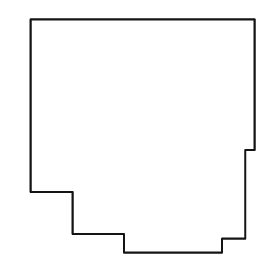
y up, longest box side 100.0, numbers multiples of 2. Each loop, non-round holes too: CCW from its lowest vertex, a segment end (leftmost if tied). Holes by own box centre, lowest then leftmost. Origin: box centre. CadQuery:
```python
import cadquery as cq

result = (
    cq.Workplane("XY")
    .moveTo(-8.0, -50.0)
    .lineTo(34.0, -50.0)
    .lineTo(34.0, -44.0)
    .lineTo(44.0, -44.0)
    .lineTo(44.0, -6.0)
    .lineTo(48.0, -6.0)
    .lineTo(48.0, 50.0)
    .lineTo(-48.0, 50.0)
    .lineTo(-48.0, -24.0)
    .lineTo(-30.0, -24.0)
    .lineTo(-30.0, -42.0)
    .lineTo(-8.0, -42.0)
    .close()
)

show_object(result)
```